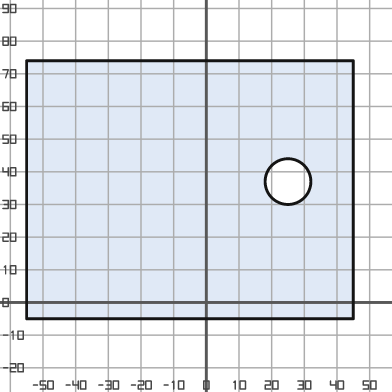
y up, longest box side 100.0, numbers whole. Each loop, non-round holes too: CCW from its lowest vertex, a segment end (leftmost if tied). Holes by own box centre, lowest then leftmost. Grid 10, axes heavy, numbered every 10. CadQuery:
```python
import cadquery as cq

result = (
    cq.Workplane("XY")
    .moveTo(-55.0, -5.0)
    .lineTo(45.0, -5.0)
    .lineTo(45.0, 74.0)
    .lineTo(-55.0, 74.0)
    .close()
    .moveTo(25.0, 37.0)
    .circle(7.0)
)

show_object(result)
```